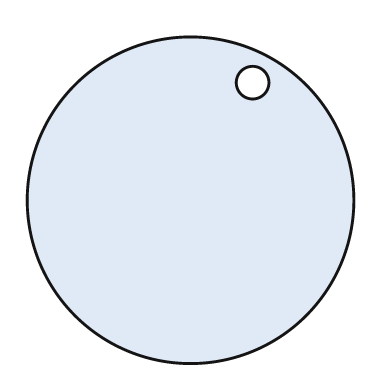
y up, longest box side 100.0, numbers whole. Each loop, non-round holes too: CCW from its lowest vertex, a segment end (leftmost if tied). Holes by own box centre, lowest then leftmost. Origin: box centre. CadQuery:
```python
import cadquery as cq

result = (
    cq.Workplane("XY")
    .moveTo(0.0, 0.0)
    .circle(50.0)
    .moveTo(19.0, 36.0)
    .circle(5.0)
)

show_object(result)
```